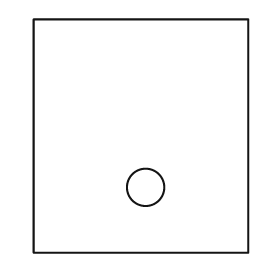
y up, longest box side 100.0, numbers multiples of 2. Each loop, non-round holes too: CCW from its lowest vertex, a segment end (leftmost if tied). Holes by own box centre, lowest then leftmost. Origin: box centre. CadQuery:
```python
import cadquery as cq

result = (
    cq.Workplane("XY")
    .moveTo(-46.0, -50.0)
    .lineTo(46.0, -50.0)
    .lineTo(46.0, 50.0)
    .lineTo(-46.0, 50.0)
    .close()
    .moveTo(2.0, -22.0)
    .circle(8.0)
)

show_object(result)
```